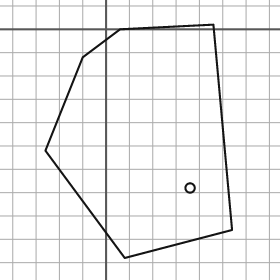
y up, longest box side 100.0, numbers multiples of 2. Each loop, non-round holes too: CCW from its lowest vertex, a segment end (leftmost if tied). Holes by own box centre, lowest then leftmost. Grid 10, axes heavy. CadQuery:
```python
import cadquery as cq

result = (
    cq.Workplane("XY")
    .moveTo(8.0, -98.0)
    .lineTo(54.0, -86.0)
    .lineTo(46.0, 2.0)
    .lineTo(6.0, 0.0)
    .lineTo(-10.0, -12.0)
    .lineTo(-26.0, -52.0)
    .close()
    .moveTo(36.0, -68.0)
    .circle(2.0)
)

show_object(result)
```